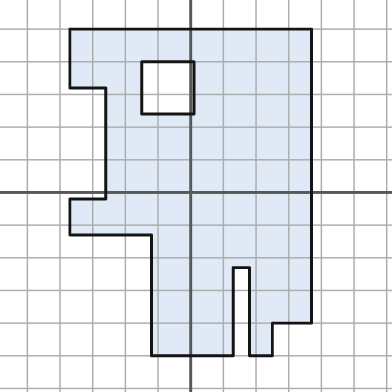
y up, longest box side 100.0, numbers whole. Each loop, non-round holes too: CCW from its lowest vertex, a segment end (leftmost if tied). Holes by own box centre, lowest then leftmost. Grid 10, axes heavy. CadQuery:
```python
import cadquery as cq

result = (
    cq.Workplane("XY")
    .moveTo(-12.0, -50.0)
    .lineTo(13.0, -50.0)
    .lineTo(13.0, -23.0)
    .lineTo(18.0, -23.0)
    .lineTo(18.0, -50.0)
    .lineTo(25.0, -50.0)
    .lineTo(25.0, -40.0)
    .lineTo(37.0, -40.0)
    .lineTo(37.0, 50.0)
    .lineTo(-37.0, 50.0)
    .lineTo(-37.0, 32.0)
    .lineTo(-26.0, 32.0)
    .lineTo(-26.0, -2.0)
    .lineTo(-37.0, -2.0)
    .lineTo(-37.0, -13.0)
    .lineTo(-12.0, -13.0)
    .close()
    .moveTo(-15.0, 24.0)
    .lineTo(1.0, 24.0)
    .lineTo(1.0, 40.0)
    .lineTo(-15.0, 40.0)
    .close()
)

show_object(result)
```